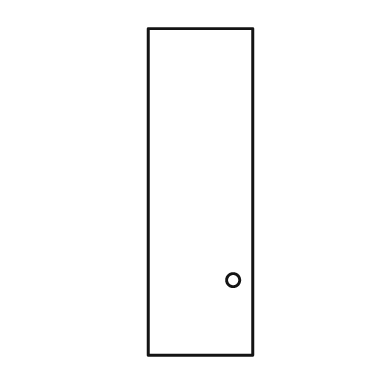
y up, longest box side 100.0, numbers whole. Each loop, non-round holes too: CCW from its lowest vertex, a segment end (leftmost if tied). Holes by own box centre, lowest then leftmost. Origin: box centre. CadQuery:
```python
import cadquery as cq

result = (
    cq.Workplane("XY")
    .moveTo(-16.0, -50.0)
    .lineTo(16.0, -50.0)
    .lineTo(16.0, 50.0)
    .lineTo(-16.0, 50.0)
    .close()
    .moveTo(10.0, -27.0)
    .circle(2.0)
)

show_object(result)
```